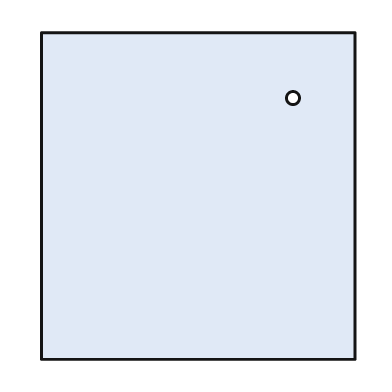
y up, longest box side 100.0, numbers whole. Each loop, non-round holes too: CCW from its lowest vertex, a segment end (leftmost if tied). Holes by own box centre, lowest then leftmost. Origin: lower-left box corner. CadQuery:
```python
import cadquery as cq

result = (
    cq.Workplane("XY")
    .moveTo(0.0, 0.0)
    .lineTo(96.0, 0.0)
    .lineTo(96.0, 100.0)
    .lineTo(0.0, 100.0)
    .close()
    .moveTo(77.0, 80.0)
    .circle(2.0)
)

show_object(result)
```